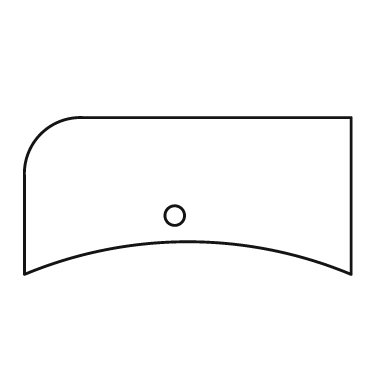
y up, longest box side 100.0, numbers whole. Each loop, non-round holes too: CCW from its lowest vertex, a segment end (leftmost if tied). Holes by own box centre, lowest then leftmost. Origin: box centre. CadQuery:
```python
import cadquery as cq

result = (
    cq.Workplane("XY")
    .moveTo(-50.0, -24.0)
    .threePointArc((0.0, -14.0), (50.0, -24.0))
    .lineTo(50.0, 24.0)
    .lineTo(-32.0, 24.0)
    .threePointArc((-45.0, 19.0), (-50.0, 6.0))
    .close()
    .moveTo(-4.0, -6.0)
    .circle(3.0)
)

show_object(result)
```